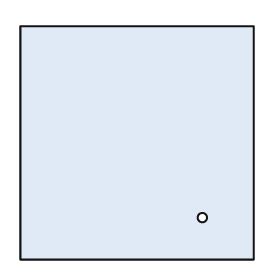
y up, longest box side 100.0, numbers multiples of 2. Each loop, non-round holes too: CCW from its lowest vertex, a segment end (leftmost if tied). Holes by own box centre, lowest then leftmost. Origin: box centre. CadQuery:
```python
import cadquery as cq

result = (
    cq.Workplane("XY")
    .moveTo(-50.0, -50.0)
    .lineTo(50.0, -50.0)
    .lineTo(50.0, 50.0)
    .lineTo(-50.0, 50.0)
    .close()
    .moveTo(28.0, -32.0)
    .circle(2.0)
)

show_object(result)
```